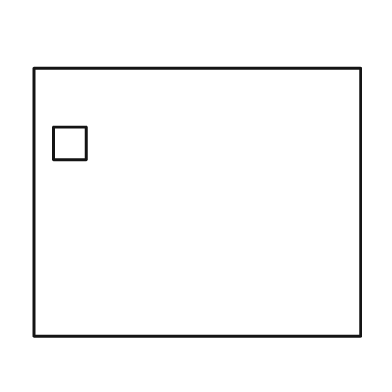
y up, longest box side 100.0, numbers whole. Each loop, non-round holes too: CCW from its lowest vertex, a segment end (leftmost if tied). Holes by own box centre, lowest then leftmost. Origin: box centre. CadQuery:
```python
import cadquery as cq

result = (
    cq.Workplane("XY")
    .moveTo(-50.0, -41.0)
    .lineTo(50.0, -41.0)
    .lineTo(50.0, 41.0)
    .lineTo(-50.0, 41.0)
    .close()
    .moveTo(-44.0, 13.0)
    .lineTo(-34.0, 13.0)
    .lineTo(-34.0, 23.0)
    .lineTo(-44.0, 23.0)
    .close()
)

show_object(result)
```